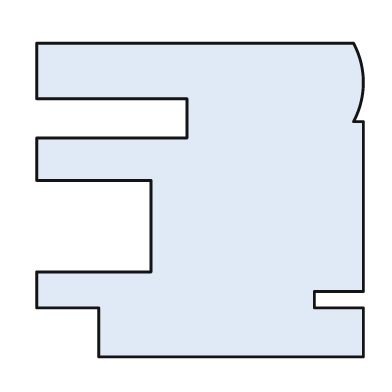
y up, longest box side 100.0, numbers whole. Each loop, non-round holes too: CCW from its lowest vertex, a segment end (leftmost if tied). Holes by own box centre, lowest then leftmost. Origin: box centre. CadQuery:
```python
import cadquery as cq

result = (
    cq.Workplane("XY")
    .moveTo(-31.0, -48.0)
    .lineTo(50.0, -48.0)
    .lineTo(50.0, -33.0)
    .lineTo(35.0, -33.0)
    .lineTo(35.0, -28.0)
    .lineTo(50.0, -28.0)
    .lineTo(50.0, 24.0)
    .lineTo(47.0, 24.0)
    .threePointArc((50.0, 36.0), (47.0, 48.0))
    .lineTo(-50.0, 48.0)
    .lineTo(-50.0, 31.0)
    .lineTo(-4.0, 31.0)
    .lineTo(-4.0, 19.0)
    .lineTo(-50.0, 19.0)
    .lineTo(-50.0, 6.0)
    .lineTo(-15.0, 6.0)
    .lineTo(-15.0, -22.0)
    .lineTo(-50.0, -22.0)
    .lineTo(-50.0, -33.0)
    .lineTo(-31.0, -33.0)
    .close()
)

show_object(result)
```